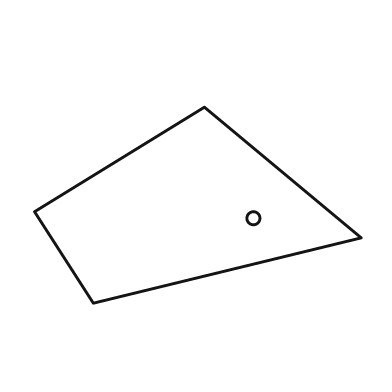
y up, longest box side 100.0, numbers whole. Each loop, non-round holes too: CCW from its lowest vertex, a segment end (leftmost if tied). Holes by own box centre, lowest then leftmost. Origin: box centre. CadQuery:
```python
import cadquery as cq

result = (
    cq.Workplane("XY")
    .moveTo(-32.0, -30.0)
    .lineTo(50.0, -10.0)
    .lineTo(2.0, 30.0)
    .lineTo(-50.0, -2.0)
    .close()
    .moveTo(17.0, -4.0)
    .circle(2.0)
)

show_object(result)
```